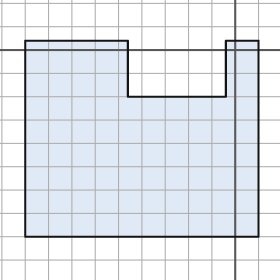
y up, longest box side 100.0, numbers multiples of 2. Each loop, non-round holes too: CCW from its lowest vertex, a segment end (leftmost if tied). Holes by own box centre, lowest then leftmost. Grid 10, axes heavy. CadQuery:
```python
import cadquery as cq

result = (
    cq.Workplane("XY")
    .moveTo(-90.0, -80.0)
    .lineTo(10.0, -80.0)
    .lineTo(10.0, 4.0)
    .lineTo(-4.0, 4.0)
    .lineTo(-4.0, -20.0)
    .lineTo(-46.0, -20.0)
    .lineTo(-46.0, 4.0)
    .lineTo(-90.0, 4.0)
    .close()
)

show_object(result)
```